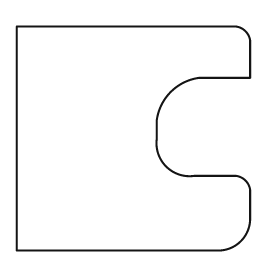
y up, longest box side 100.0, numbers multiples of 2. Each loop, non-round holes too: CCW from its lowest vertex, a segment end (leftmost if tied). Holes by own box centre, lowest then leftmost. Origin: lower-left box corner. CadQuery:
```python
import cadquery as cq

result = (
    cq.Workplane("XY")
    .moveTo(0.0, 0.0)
    .lineTo(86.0, 0.0)
    .threePointArc((96.0, 4.0), (100.0, 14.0))
    .lineTo(100.0, 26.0)
    .threePointArc((98.0, 30.0), (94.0, 32.0))
    .lineTo(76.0, 32.0)
    .threePointArc((64.0, 36.0), (60.0, 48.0))
    .lineTo(60.0, 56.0)
    .threePointArc((66.0, 68.0), (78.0, 74.0))
    .lineTo(100.0, 74.0)
    .lineTo(100.0, 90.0)
    .threePointArc((98.0, 94.0), (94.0, 96.0))
    .lineTo(0.0, 96.0)
    .close()
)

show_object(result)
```